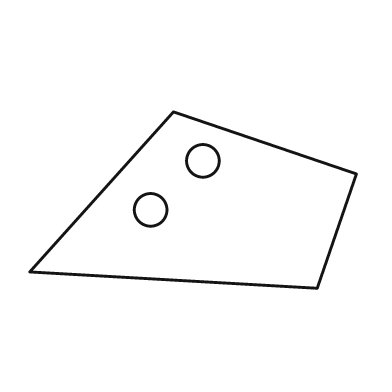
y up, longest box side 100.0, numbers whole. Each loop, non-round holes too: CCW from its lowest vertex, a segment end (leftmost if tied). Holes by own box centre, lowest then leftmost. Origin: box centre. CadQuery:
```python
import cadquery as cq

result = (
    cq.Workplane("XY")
    .moveTo(38.0, -27.0)
    .lineTo(50.0, 8.0)
    .lineTo(-6.0, 27.0)
    .lineTo(-50.0, -22.0)
    .close()
    .moveTo(-13.0, -3.0)
    .circle(5.0)
    .moveTo(3.0, 12.0)
    .circle(5.0)
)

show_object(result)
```